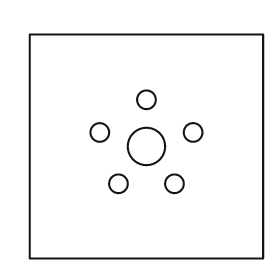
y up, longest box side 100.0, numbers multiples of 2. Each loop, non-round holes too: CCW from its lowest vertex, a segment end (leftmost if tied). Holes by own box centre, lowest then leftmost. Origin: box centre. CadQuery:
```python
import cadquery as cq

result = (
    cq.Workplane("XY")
    .moveTo(-50.0, -48.0)
    .lineTo(50.0, -48.0)
    .lineTo(50.0, 48.0)
    .lineTo(-50.0, 48.0)
    .close()
    .moveTo(-12.0, -16.0)
    .circle(4.0)
    .moveTo(12.0, -16.0)
    .circle(4.0)
    .moveTo(0.0, 0.0)
    .circle(8.0)
    .moveTo(-20.0, 6.0)
    .circle(4.0)
    .moveTo(20.0, 6.0)
    .circle(4.0)
    .moveTo(0.0, 20.0)
    .circle(4.0)
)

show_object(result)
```